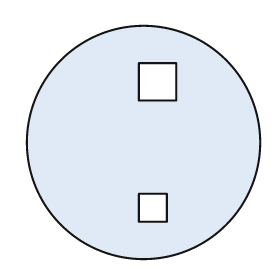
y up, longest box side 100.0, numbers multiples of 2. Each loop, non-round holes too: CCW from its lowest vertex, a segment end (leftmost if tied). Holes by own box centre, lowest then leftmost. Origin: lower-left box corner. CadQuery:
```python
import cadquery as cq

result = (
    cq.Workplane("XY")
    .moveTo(50.0, 50.0)
    .circle(50.0)
    .moveTo(48.0, 16.0)
    .lineTo(60.0, 16.0)
    .lineTo(60.0, 28.0)
    .lineTo(48.0, 28.0)
    .close()
    .moveTo(48.0, 68.0)
    .lineTo(64.0, 68.0)
    .lineTo(64.0, 84.0)
    .lineTo(48.0, 84.0)
    .close()
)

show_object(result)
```